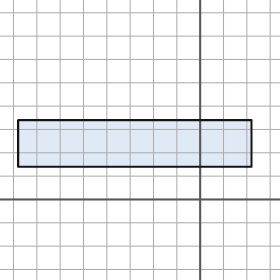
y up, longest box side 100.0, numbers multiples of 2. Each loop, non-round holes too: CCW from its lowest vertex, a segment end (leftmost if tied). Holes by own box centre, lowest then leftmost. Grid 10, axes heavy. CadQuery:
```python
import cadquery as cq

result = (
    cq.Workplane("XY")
    .moveTo(-78.0, 14.0)
    .lineTo(22.0, 14.0)
    .lineTo(22.0, 34.0)
    .lineTo(-78.0, 34.0)
    .close()
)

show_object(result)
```